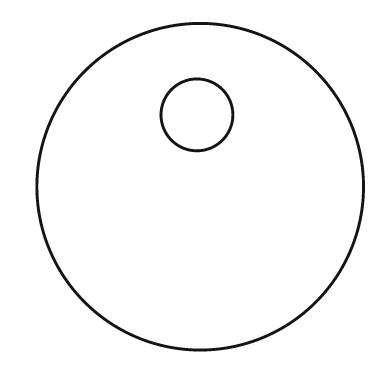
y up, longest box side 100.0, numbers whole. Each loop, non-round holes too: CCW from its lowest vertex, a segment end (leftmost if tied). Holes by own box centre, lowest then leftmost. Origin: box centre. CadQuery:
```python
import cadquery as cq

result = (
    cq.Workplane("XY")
    .moveTo(0.0, 0.0)
    .circle(50.0)
    .moveTo(-1.0, 22.0)
    .circle(11.0)
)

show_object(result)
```